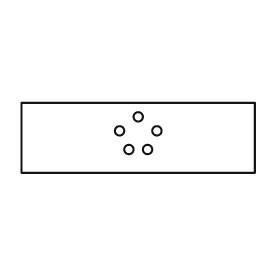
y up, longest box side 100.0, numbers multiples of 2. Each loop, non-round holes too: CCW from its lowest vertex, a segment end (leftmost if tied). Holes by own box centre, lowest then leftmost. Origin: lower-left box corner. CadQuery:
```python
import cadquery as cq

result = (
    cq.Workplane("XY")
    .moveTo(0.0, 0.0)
    .lineTo(100.0, 0.0)
    .lineTo(100.0, 30.0)
    .lineTo(0.0, 30.0)
    .close()
    .moveTo(46.0, 10.0)
    .circle(2.0)
    .moveTo(54.0, 10.0)
    .circle(2.0)
    .moveTo(42.0, 18.0)
    .circle(2.0)
    .moveTo(58.0, 18.0)
    .circle(2.0)
    .moveTo(50.0, 24.0)
    .circle(2.0)
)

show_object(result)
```